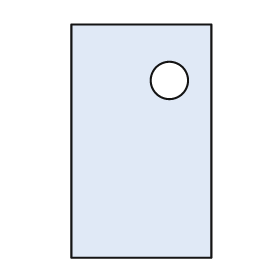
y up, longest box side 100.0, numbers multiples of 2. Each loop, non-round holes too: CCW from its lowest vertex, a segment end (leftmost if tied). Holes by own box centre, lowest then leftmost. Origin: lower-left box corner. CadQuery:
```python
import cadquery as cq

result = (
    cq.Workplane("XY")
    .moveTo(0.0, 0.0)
    .lineTo(60.0, 0.0)
    .lineTo(60.0, 100.0)
    .lineTo(0.0, 100.0)
    .close()
    .moveTo(42.0, 76.0)
    .circle(8.0)
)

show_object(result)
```